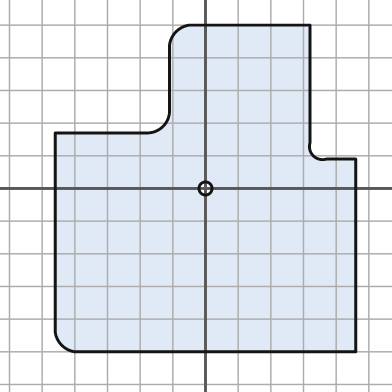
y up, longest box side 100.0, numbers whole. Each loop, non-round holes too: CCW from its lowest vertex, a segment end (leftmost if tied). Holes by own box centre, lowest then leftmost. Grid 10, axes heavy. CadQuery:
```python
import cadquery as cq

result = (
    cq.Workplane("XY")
    .moveTo(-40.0, -50.0)
    .lineTo(46.0, -50.0)
    .lineTo(46.0, 9.0)
    .lineTo(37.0, 9.0)
    .threePointArc((33.0, 10.0), (32.0, 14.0))
    .lineTo(32.0, 50.0)
    .lineTo(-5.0, 50.0)
    .threePointArc((-9.0, 48.0), (-11.0, 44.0))
    .lineTo(-11.0, 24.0)
    .threePointArc((-13.0, 19.0), (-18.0, 17.0))
    .lineTo(-46.0, 17.0)
    .lineTo(-46.0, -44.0)
    .threePointArc((-44.0, -48.0), (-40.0, -50.0))
    .close()
    .moveTo(0.0, 0.0)
    .circle(2.0)
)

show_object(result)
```